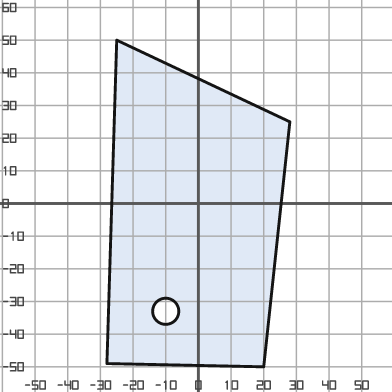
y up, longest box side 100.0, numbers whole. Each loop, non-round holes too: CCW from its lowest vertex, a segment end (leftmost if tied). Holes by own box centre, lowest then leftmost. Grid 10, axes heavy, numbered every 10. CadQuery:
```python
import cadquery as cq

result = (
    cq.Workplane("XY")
    .moveTo(20.0, -50.0)
    .lineTo(28.0, 25.0)
    .lineTo(-25.0, 50.0)
    .lineTo(-28.0, -49.0)
    .close()
    .moveTo(-10.0, -33.0)
    .circle(4.0)
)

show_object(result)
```